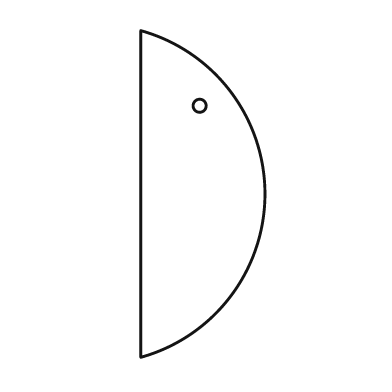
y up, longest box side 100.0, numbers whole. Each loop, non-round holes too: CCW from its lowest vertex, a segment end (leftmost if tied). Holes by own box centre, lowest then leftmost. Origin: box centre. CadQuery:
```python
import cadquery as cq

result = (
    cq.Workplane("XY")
    .moveTo(-19.0, -50.0)
    .threePointArc((19.0, 0.0), (-19.0, 50.0))
    .close()
    .moveTo(-1.0, 27.0)
    .circle(2.0)
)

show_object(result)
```